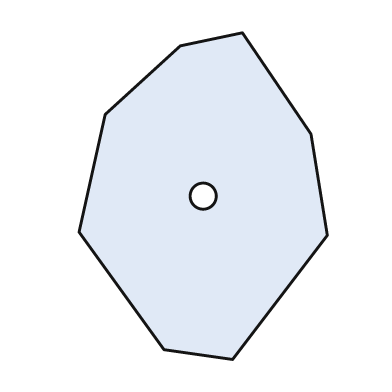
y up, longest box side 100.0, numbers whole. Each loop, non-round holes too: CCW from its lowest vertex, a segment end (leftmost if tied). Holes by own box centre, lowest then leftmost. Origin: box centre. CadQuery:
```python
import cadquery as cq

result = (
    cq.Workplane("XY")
    .moveTo(9.0, -50.0)
    .lineTo(38.0, -12.0)
    .lineTo(33.0, 19.0)
    .lineTo(12.0, 50.0)
    .lineTo(-7.0, 46.0)
    .lineTo(-30.0, 25.0)
    .lineTo(-38.0, -11.0)
    .lineTo(-12.0, -47.0)
    .close()
    .moveTo(0.0, 0.0)
    .circle(4.0)
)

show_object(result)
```